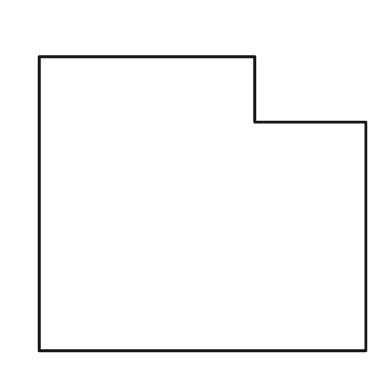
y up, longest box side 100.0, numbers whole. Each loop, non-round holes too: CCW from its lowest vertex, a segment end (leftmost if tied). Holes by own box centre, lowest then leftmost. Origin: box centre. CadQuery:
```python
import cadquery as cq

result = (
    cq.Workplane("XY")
    .moveTo(-50.0, -45.0)
    .lineTo(50.0, -45.0)
    .lineTo(50.0, 25.0)
    .lineTo(16.0, 25.0)
    .lineTo(16.0, 45.0)
    .lineTo(-50.0, 45.0)
    .close()
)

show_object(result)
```